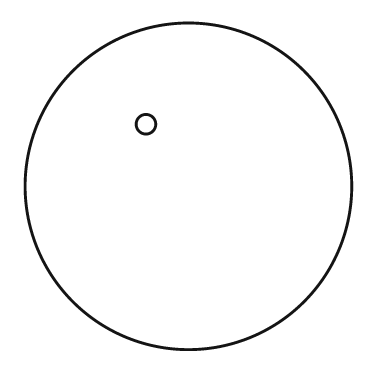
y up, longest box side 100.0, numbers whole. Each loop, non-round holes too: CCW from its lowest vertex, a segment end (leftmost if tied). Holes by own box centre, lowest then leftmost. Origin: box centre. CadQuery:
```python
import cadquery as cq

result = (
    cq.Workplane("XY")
    .moveTo(0.0, 0.0)
    .circle(50.0)
    .moveTo(-13.0, 19.0)
    .circle(3.0)
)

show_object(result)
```